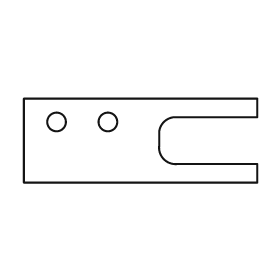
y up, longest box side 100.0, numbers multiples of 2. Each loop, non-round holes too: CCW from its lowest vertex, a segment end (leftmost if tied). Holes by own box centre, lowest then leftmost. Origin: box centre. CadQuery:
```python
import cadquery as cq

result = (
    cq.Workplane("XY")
    .moveTo(-50.0, -18.0)
    .lineTo(50.0, -18.0)
    .lineTo(50.0, -10.0)
    .lineTo(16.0, -10.0)
    .threePointArc((10.0, -8.0), (8.0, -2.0))
    .lineTo(8.0, 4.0)
    .threePointArc((10.0, 8.0), (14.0, 10.0))
    .lineTo(50.0, 10.0)
    .lineTo(50.0, 18.0)
    .lineTo(-50.0, 18.0)
    .close()
    .moveTo(-36.0, 8.0)
    .circle(4.0)
    .moveTo(-14.0, 8.0)
    .circle(4.0)
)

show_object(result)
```